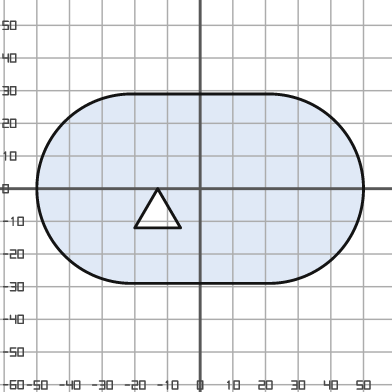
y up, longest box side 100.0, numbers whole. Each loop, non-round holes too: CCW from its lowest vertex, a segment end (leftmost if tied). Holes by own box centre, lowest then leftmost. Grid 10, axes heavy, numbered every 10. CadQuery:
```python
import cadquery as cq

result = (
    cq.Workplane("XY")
    .moveTo(-21.0, -29.0)
    .lineTo(21.0, -29.0)
    .threePointArc((50.0, 0.0), (21.0, 29.0))
    .lineTo(-21.0, 29.0)
    .threePointArc((-50.0, 0.0), (-21.0, -29.0))
    .close()
    .moveTo(-20.0, -12.0)
    .lineTo(-6.0, -12.0)
    .lineTo(-13.0, 0.0)
    .close()
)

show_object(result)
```